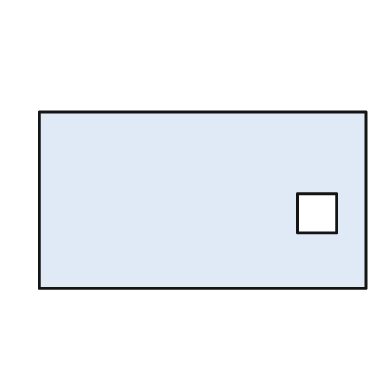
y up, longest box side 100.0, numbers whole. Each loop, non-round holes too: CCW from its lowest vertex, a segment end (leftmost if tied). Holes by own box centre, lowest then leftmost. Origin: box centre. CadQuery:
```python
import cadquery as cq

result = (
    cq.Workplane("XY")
    .moveTo(-50.0, -27.0)
    .lineTo(50.0, -27.0)
    .lineTo(50.0, 27.0)
    .lineTo(-50.0, 27.0)
    .close()
    .moveTo(29.0, -10.0)
    .lineTo(41.0, -10.0)
    .lineTo(41.0, 2.0)
    .lineTo(29.0, 2.0)
    .close()
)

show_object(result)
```